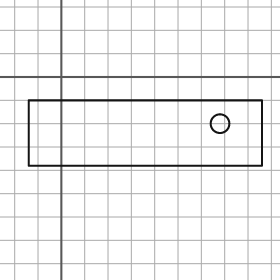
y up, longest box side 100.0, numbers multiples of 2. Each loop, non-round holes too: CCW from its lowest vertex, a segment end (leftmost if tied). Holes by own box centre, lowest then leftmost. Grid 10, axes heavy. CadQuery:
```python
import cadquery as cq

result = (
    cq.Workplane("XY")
    .moveTo(-14.0, -38.0)
    .lineTo(86.0, -38.0)
    .lineTo(86.0, -10.0)
    .lineTo(-14.0, -10.0)
    .close()
    .moveTo(68.0, -20.0)
    .circle(4.0)
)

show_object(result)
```